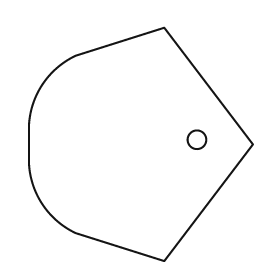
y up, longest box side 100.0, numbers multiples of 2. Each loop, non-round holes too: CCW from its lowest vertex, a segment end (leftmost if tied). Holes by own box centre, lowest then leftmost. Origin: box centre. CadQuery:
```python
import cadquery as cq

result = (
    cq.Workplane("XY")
    .moveTo(10.0, -50.0)
    .lineTo(48.0, 0.0)
    .lineTo(10.0, 50.0)
    .lineTo(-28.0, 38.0)
    .threePointArc((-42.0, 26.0), (-48.0, 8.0))
    .lineTo(-48.0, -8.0)
    .threePointArc((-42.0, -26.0), (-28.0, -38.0))
    .close()
    .moveTo(24.0, 2.0)
    .circle(4.0)
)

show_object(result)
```